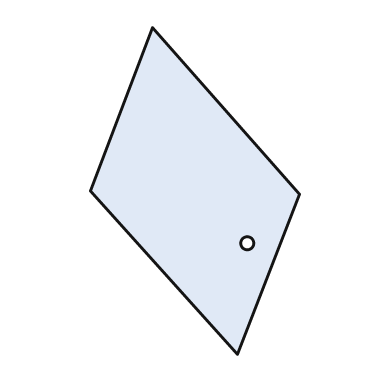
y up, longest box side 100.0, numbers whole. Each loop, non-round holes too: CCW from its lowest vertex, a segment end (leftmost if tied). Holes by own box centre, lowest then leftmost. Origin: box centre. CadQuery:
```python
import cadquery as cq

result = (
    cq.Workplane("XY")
    .moveTo(13.0, -50.0)
    .lineTo(32.0, -1.0)
    .lineTo(-13.0, 50.0)
    .lineTo(-32.0, 0.0)
    .close()
    .moveTo(16.0, -16.0)
    .circle(2.0)
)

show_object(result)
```